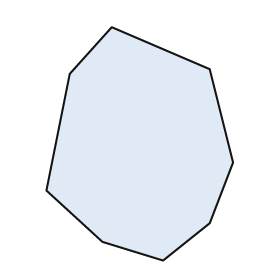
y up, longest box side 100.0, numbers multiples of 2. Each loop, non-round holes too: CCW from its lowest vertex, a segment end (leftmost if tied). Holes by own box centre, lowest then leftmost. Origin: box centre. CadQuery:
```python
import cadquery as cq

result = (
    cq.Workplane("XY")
    .moveTo(10.0, -50.0)
    .lineTo(30.0, -34.0)
    .lineTo(40.0, -8.0)
    .lineTo(30.0, 32.0)
    .lineTo(-12.0, 50.0)
    .lineTo(-30.0, 30.0)
    .lineTo(-40.0, -20.0)
    .lineTo(-16.0, -42.0)
    .close()
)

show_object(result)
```